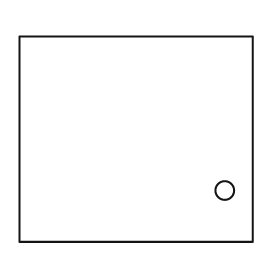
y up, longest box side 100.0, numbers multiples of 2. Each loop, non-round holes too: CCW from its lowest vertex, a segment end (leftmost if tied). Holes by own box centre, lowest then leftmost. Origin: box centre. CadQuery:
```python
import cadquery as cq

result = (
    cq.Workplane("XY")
    .moveTo(-50.0, -44.0)
    .lineTo(50.0, -44.0)
    .lineTo(50.0, 44.0)
    .lineTo(-50.0, 44.0)
    .close()
    .moveTo(38.0, -22.0)
    .circle(4.0)
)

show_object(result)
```